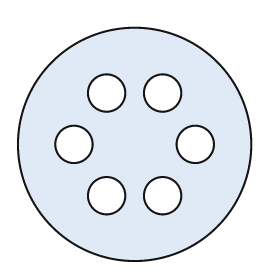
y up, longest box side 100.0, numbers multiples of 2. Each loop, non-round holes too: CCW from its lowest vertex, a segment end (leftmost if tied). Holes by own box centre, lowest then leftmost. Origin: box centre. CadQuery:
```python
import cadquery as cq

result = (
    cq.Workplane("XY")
    .moveTo(0.0, 0.0)
    .circle(50.0)
    .moveTo(-12.0, -22.0)
    .circle(8.0)
    .moveTo(12.0, -22.0)
    .circle(8.0)
    .moveTo(-26.0, 0.0)
    .circle(8.0)
    .moveTo(26.0, 0.0)
    .circle(8.0)
    .moveTo(-12.0, 22.0)
    .circle(8.0)
    .moveTo(12.0, 22.0)
    .circle(8.0)
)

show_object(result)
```